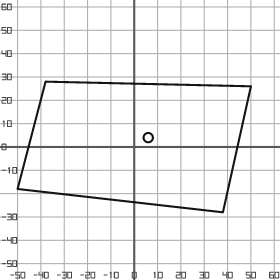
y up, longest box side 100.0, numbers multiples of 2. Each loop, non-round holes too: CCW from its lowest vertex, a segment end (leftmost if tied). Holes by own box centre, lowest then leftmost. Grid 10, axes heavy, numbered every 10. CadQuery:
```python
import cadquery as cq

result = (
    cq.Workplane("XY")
    .moveTo(38.0, -28.0)
    .lineTo(50.0, 26.0)
    .lineTo(-38.0, 28.0)
    .lineTo(-50.0, -18.0)
    .close()
    .moveTo(6.0, 4.0)
    .circle(2.0)
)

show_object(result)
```